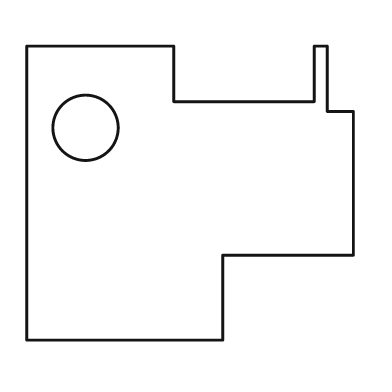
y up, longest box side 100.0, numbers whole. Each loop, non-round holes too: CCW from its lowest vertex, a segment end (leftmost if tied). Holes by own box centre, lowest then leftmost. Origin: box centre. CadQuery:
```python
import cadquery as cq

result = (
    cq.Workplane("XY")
    .moveTo(-50.0, -45.0)
    .lineTo(10.0, -45.0)
    .lineTo(10.0, -19.0)
    .lineTo(50.0, -19.0)
    .lineTo(50.0, 25.0)
    .lineTo(42.0, 25.0)
    .lineTo(42.0, 45.0)
    .lineTo(38.0, 45.0)
    .lineTo(38.0, 28.0)
    .lineTo(-5.0, 28.0)
    .lineTo(-5.0, 45.0)
    .lineTo(-50.0, 45.0)
    .close()
    .moveTo(-32.0, 20.0)
    .circle(10.0)
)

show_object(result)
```